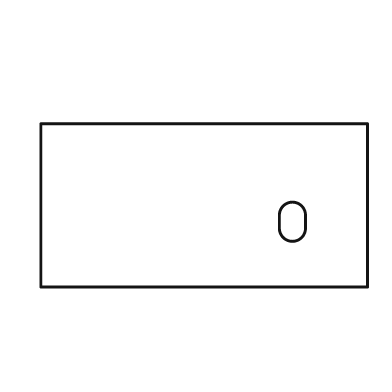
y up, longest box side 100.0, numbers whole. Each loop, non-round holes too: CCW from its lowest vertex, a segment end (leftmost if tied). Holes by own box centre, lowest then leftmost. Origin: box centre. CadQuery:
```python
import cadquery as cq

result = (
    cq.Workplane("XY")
    .moveTo(-50.0, -25.0)
    .lineTo(50.0, -25.0)
    .lineTo(50.0, 25.0)
    .lineTo(-50.0, 25.0)
    .close()
    .moveTo(23.0, -7.0)
    .threePointArc((27.0, -11.0), (31.0, -7.0))
    .lineTo(31.0, -3.0)
    .threePointArc((27.0, 1.0), (23.0, -3.0))
    .close()
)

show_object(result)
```